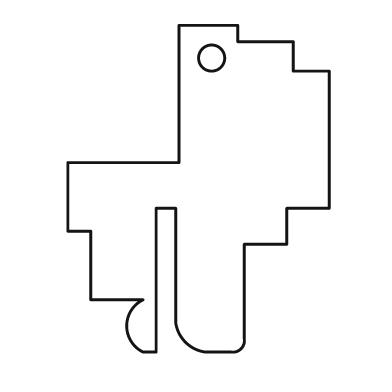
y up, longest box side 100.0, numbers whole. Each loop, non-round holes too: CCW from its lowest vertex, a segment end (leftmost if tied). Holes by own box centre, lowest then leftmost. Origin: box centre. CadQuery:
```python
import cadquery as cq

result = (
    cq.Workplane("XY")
    .moveTo(-17.0, -50.0)
    .lineTo(-13.0, -50.0)
    .lineTo(-13.0, -6.0)
    .lineTo(-7.0, -6.0)
    .lineTo(-7.0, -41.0)
    .threePointArc((-4.0, -47.0), (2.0, -50.0))
    .lineTo(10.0, -50.0)
    .threePointArc((13.0, -49.0), (14.0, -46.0))
    .lineTo(14.0, -17.0)
    .lineTo(27.0, -17.0)
    .lineTo(27.0, -6.0)
    .lineTo(40.0, -6.0)
    .lineTo(40.0, 36.0)
    .lineTo(29.0, 36.0)
    .lineTo(29.0, 45.0)
    .lineTo(12.0, 45.0)
    .lineTo(12.0, 50.0)
    .lineTo(-6.0, 50.0)
    .lineTo(-6.0, 8.0)
    .lineTo(-40.0, 8.0)
    .lineTo(-40.0, -13.0)
    .lineTo(-33.0, -13.0)
    .lineTo(-33.0, -34.0)
    .lineTo(-17.0, -34.0)
    .threePointArc((-22.0, -42.0), (-17.0, -50.0))
    .close()
    .moveTo(4.0, 40.0)
    .circle(4.0)
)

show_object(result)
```